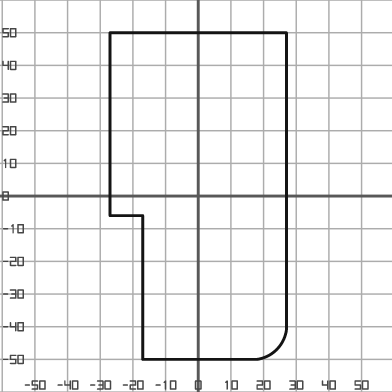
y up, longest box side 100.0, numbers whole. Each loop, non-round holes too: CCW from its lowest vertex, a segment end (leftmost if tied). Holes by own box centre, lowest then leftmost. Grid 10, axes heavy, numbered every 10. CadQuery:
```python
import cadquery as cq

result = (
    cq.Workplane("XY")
    .moveTo(-17.0, -50.0)
    .lineTo(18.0, -50.0)
    .threePointArc((24.0, -47.0), (27.0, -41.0))
    .lineTo(27.0, 50.0)
    .lineTo(-27.0, 50.0)
    .lineTo(-27.0, -6.0)
    .lineTo(-17.0, -6.0)
    .close()
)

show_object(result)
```